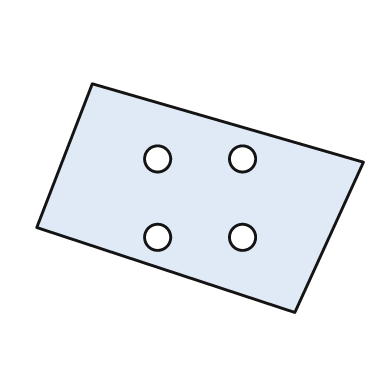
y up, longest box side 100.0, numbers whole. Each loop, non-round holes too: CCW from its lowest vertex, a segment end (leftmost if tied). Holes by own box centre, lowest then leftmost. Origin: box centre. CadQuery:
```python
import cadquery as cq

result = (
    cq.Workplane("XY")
    .moveTo(29.0, -35.0)
    .lineTo(50.0, 11.0)
    .lineTo(-33.0, 35.0)
    .lineTo(-50.0, -9.0)
    .close()
    .moveTo(-13.0, -12.0)
    .circle(4.0)
    .moveTo(13.0, -12.0)
    .circle(4.0)
    .moveTo(-13.0, 12.0)
    .circle(4.0)
    .moveTo(13.0, 12.0)
    .circle(4.0)
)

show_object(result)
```